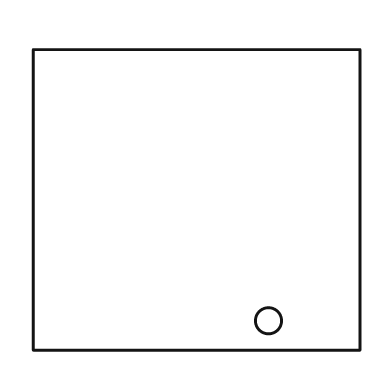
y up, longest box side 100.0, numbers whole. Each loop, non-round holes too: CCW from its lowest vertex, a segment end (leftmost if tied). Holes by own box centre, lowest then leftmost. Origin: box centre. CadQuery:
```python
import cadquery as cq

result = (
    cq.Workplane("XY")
    .moveTo(-50.0, -46.0)
    .lineTo(50.0, -46.0)
    .lineTo(50.0, 46.0)
    .lineTo(-50.0, 46.0)
    .close()
    .moveTo(22.0, -37.0)
    .circle(4.0)
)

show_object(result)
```